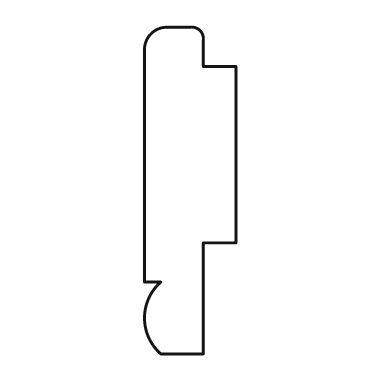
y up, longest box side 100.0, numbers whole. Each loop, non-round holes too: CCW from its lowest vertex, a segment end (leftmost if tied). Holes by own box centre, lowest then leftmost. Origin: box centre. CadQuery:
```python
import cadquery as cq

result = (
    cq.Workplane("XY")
    .moveTo(-9.0, -50.0)
    .lineTo(4.0, -50.0)
    .lineTo(4.0, -16.0)
    .lineTo(14.0, -16.0)
    .lineTo(14.0, 38.0)
    .lineTo(4.0, 38.0)
    .lineTo(4.0, 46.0)
    .threePointArc((3.0, 49.0), (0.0, 50.0))
    .lineTo(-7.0, 50.0)
    .threePointArc((-12.0, 48.0), (-14.0, 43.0))
    .lineTo(-14.0, -28.0)
    .lineTo(-9.0, -28.0)
    .threePointArc((-14.0, -39.0), (-9.0, -50.0))
    .close()
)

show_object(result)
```